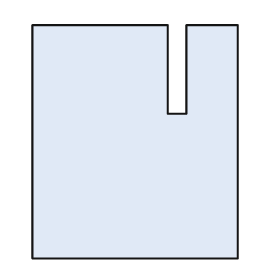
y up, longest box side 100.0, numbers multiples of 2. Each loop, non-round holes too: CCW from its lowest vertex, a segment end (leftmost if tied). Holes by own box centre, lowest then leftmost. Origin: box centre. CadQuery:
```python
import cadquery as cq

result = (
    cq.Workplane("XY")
    .moveTo(-44.0, -50.0)
    .lineTo(44.0, -50.0)
    .lineTo(44.0, 50.0)
    .lineTo(22.0, 50.0)
    .lineTo(22.0, 12.0)
    .lineTo(14.0, 12.0)
    .lineTo(14.0, 50.0)
    .lineTo(-44.0, 50.0)
    .close()
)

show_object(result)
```